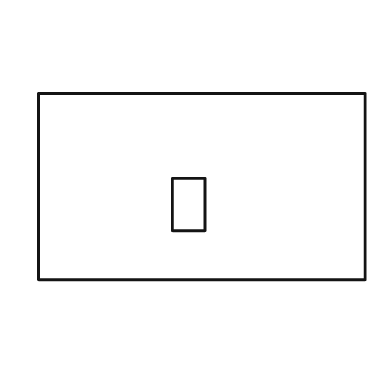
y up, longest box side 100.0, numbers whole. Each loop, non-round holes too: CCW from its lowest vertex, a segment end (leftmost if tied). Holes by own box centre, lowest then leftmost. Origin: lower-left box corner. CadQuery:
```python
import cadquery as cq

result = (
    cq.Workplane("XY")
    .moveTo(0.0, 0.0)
    .lineTo(100.0, 0.0)
    .lineTo(100.0, 57.0)
    .lineTo(0.0, 57.0)
    .close()
    .moveTo(41.0, 15.0)
    .lineTo(51.0, 15.0)
    .lineTo(51.0, 31.0)
    .lineTo(41.0, 31.0)
    .close()
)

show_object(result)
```